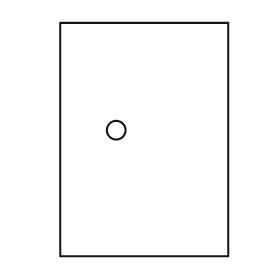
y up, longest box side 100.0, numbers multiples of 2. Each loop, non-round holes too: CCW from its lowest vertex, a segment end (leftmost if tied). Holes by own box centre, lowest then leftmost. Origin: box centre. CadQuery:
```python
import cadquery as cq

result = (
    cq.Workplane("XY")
    .moveTo(-36.0, -50.0)
    .lineTo(36.0, -50.0)
    .lineTo(36.0, 50.0)
    .lineTo(-36.0, 50.0)
    .close()
    .moveTo(-12.0, 4.0)
    .circle(4.0)
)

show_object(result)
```